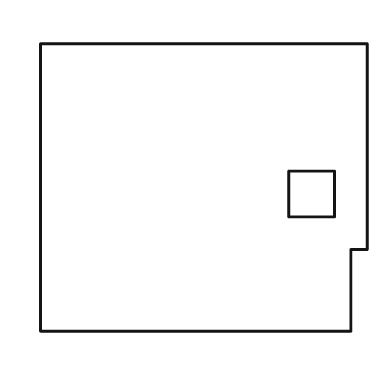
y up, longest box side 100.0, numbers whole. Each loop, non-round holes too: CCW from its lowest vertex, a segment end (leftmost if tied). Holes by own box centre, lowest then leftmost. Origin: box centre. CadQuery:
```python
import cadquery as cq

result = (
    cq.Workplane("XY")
    .moveTo(-50.0, -44.0)
    .lineTo(45.0, -44.0)
    .lineTo(45.0, -19.0)
    .lineTo(50.0, -19.0)
    .lineTo(50.0, 44.0)
    .lineTo(-50.0, 44.0)
    .close()
    .moveTo(26.0, -9.0)
    .lineTo(40.0, -9.0)
    .lineTo(40.0, 5.0)
    .lineTo(26.0, 5.0)
    .close()
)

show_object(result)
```